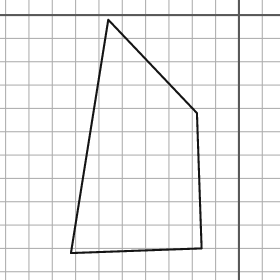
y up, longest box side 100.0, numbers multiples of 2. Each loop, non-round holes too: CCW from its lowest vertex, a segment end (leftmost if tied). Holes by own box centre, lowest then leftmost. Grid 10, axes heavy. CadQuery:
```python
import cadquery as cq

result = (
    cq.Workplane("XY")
    .moveTo(-72.0, -102.0)
    .lineTo(-16.0, -100.0)
    .lineTo(-18.0, -42.0)
    .lineTo(-56.0, -2.0)
    .close()
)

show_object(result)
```